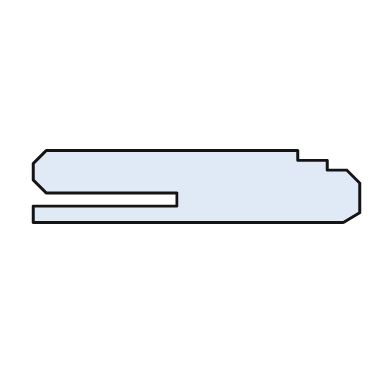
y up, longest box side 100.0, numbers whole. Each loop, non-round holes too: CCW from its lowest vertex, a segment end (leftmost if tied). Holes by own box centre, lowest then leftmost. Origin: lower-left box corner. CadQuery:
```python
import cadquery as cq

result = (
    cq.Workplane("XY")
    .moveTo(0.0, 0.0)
    .lineTo(95.0, 0.0)
    .lineTo(100.0, 3.0)
    .lineTo(100.0, 12.0)
    .lineTo(96.0, 16.0)
    .lineTo(90.0, 16.0)
    .lineTo(90.0, 19.0)
    .lineTo(81.0, 19.0)
    .lineTo(81.0, 22.0)
    .lineTo(4.0, 22.0)
    .lineTo(0.0, 18.0)
    .lineTo(0.0, 13.0)
    .lineTo(4.0, 9.0)
    .lineTo(44.0, 9.0)
    .lineTo(44.0, 5.0)
    .lineTo(0.0, 5.0)
    .close()
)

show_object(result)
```